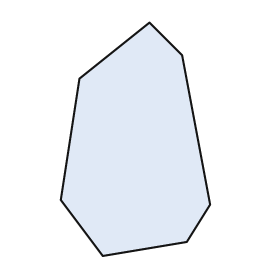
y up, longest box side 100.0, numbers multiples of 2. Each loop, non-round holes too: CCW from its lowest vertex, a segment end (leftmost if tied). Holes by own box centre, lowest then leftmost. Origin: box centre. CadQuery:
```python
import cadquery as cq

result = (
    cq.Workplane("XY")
    .moveTo(-14.0, -50.0)
    .lineTo(22.0, -44.0)
    .lineTo(32.0, -28.0)
    .lineTo(20.0, 36.0)
    .lineTo(6.0, 50.0)
    .lineTo(-24.0, 26.0)
    .lineTo(-32.0, -26.0)
    .close()
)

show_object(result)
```